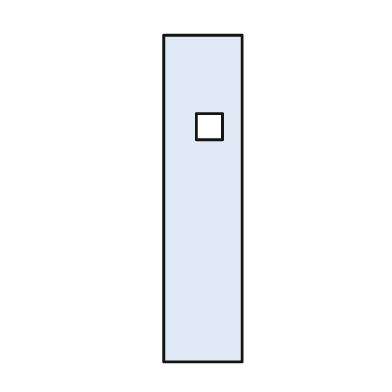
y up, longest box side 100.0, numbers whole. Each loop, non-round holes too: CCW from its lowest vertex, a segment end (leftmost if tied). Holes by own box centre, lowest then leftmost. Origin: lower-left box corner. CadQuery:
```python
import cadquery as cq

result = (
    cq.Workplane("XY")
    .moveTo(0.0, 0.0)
    .lineTo(24.0, 0.0)
    .lineTo(24.0, 100.0)
    .lineTo(0.0, 100.0)
    .close()
    .moveTo(10.0, 68.0)
    .lineTo(18.0, 68.0)
    .lineTo(18.0, 76.0)
    .lineTo(10.0, 76.0)
    .close()
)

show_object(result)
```